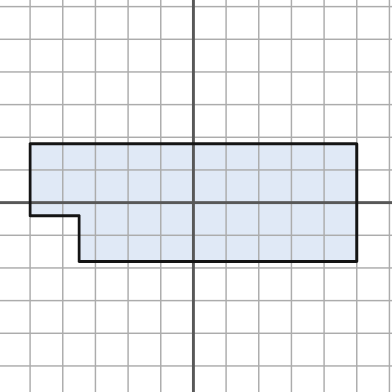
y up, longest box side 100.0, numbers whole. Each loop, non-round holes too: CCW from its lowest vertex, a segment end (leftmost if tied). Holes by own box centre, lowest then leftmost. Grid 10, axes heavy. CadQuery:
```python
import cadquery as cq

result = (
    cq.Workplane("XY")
    .moveTo(-35.0, -18.0)
    .lineTo(50.0, -18.0)
    .lineTo(50.0, 18.0)
    .lineTo(-50.0, 18.0)
    .lineTo(-50.0, -4.0)
    .lineTo(-35.0, -4.0)
    .close()
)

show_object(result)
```